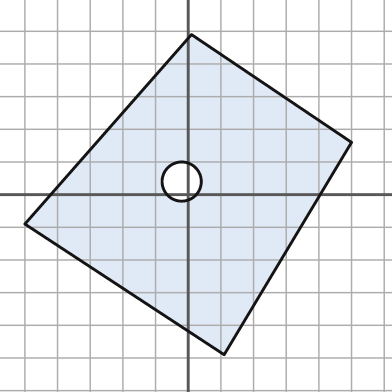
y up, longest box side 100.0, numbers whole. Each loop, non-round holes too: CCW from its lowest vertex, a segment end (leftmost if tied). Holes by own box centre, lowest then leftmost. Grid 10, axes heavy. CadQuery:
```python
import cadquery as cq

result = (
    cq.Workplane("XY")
    .moveTo(11.0, -49.0)
    .lineTo(50.0, 16.0)
    .lineTo(1.0, 49.0)
    .lineTo(-50.0, -9.0)
    .close()
    .moveTo(-2.0, 4.0)
    .circle(6.0)
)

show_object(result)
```